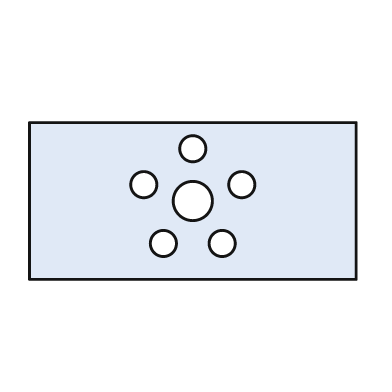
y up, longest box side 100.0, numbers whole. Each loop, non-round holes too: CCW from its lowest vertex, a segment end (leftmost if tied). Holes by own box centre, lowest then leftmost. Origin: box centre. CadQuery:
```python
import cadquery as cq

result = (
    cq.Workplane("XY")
    .moveTo(-50.0, -24.0)
    .lineTo(50.0, -24.0)
    .lineTo(50.0, 24.0)
    .lineTo(-50.0, 24.0)
    .close()
    .moveTo(-9.0, -13.0)
    .circle(4.0)
    .moveTo(9.0, -13.0)
    .circle(4.0)
    .moveTo(0.0, 0.0)
    .circle(6.0)
    .moveTo(-15.0, 5.0)
    .circle(4.0)
    .moveTo(15.0, 5.0)
    .circle(4.0)
    .moveTo(0.0, 16.0)
    .circle(4.0)
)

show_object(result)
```